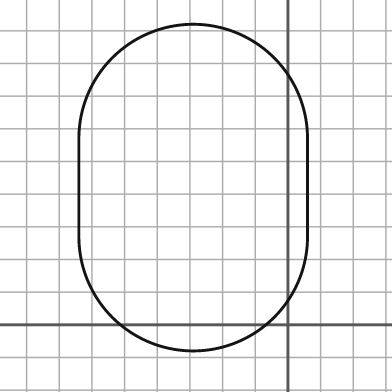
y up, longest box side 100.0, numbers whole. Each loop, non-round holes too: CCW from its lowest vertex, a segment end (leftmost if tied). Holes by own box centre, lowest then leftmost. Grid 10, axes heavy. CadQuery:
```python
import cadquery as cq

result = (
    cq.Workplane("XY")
    .moveTo(-64.0, 27.0)
    .threePointArc((-29.0, -8.0), (6.0, 27.0))
    .lineTo(6.0, 57.0)
    .threePointArc((-29.0, 92.0), (-64.0, 57.0))
    .close()
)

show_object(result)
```